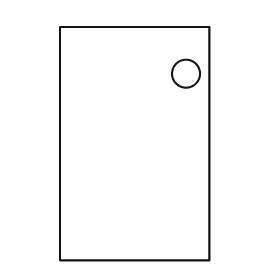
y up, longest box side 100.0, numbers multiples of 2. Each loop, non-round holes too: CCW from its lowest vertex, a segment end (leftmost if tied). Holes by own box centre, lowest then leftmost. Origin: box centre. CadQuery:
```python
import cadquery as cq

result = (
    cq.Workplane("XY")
    .moveTo(-32.0, -50.0)
    .lineTo(32.0, -50.0)
    .lineTo(32.0, 50.0)
    .lineTo(-32.0, 50.0)
    .close()
    .moveTo(22.0, 30.0)
    .circle(6.0)
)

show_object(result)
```